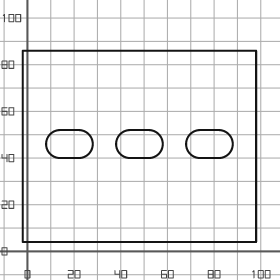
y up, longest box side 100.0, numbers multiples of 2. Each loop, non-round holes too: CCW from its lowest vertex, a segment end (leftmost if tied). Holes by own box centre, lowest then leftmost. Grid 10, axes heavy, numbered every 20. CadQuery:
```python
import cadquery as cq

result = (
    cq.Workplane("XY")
    .moveTo(-2.0, 4.0)
    .lineTo(98.0, 4.0)
    .lineTo(98.0, 86.0)
    .lineTo(-2.0, 86.0)
    .close()
    .moveTo(14.0, 40.0)
    .lineTo(22.0, 40.0)
    .threePointArc((28.0, 46.0), (22.0, 52.0))
    .lineTo(14.0, 52.0)
    .threePointArc((8.0, 46.0), (14.0, 40.0))
    .close()
    .moveTo(44.0, 40.0)
    .lineTo(52.0, 40.0)
    .threePointArc((58.0, 46.0), (52.0, 52.0))
    .lineTo(44.0, 52.0)
    .threePointArc((38.0, 46.0), (44.0, 40.0))
    .close()
    .moveTo(74.0, 40.0)
    .lineTo(82.0, 40.0)
    .threePointArc((88.0, 46.0), (82.0, 52.0))
    .lineTo(74.0, 52.0)
    .threePointArc((68.0, 46.0), (74.0, 40.0))
    .close()
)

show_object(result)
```